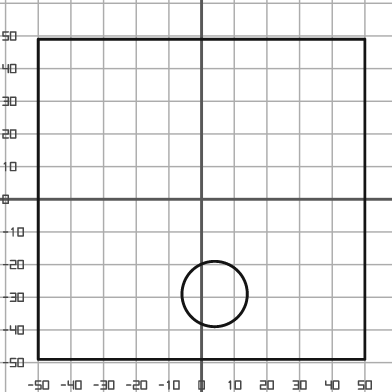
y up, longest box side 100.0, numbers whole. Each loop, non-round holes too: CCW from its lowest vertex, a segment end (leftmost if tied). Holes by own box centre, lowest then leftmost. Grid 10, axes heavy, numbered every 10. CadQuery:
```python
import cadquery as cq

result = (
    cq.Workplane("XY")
    .moveTo(-50.0, -49.0)
    .lineTo(50.0, -49.0)
    .lineTo(50.0, 49.0)
    .lineTo(-50.0, 49.0)
    .close()
    .moveTo(4.0, -29.0)
    .circle(10.0)
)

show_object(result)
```